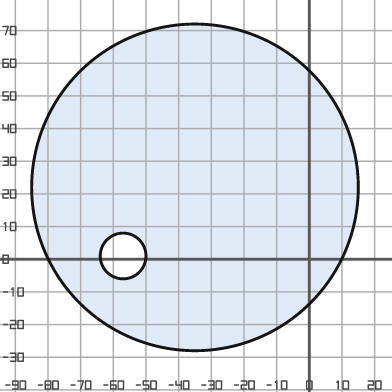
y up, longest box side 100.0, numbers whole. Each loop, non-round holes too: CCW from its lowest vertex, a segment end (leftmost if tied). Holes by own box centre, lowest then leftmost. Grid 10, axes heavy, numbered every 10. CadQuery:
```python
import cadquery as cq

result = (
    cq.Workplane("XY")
    .moveTo(-35.0, 22.0)
    .circle(50.0)
    .moveTo(-57.0, 1.0)
    .circle(7.0)
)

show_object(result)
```